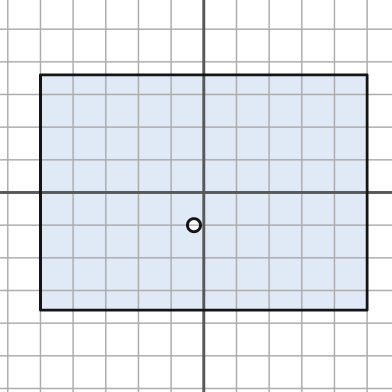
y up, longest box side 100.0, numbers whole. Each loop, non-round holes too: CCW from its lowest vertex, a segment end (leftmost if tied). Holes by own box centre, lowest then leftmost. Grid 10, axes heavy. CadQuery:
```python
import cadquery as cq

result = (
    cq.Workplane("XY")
    .moveTo(-50.0, -36.0)
    .lineTo(50.0, -36.0)
    .lineTo(50.0, 36.0)
    .lineTo(-50.0, 36.0)
    .close()
    .moveTo(-3.0, -10.0)
    .circle(2.0)
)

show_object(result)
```